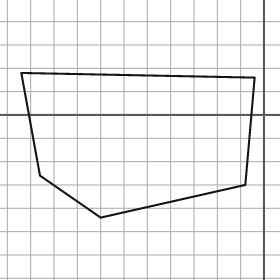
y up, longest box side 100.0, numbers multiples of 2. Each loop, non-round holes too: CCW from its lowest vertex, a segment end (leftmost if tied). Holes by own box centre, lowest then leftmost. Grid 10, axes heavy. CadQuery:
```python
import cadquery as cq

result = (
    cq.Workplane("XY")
    .moveTo(-70.0, -44.0)
    .lineTo(-8.0, -30.0)
    .lineTo(-4.0, 16.0)
    .lineTo(-104.0, 18.0)
    .lineTo(-96.0, -26.0)
    .close()
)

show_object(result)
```